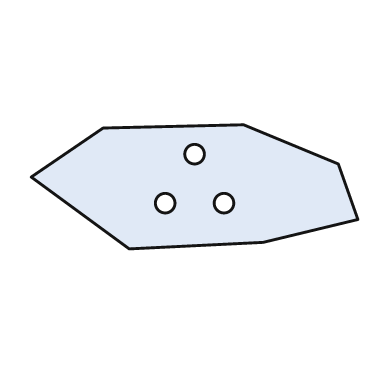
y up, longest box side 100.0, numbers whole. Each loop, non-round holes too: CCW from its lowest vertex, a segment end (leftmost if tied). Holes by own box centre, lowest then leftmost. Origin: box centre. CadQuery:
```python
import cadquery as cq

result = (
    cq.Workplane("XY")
    .moveTo(-20.0, -19.0)
    .lineTo(21.0, -17.0)
    .lineTo(50.0, -10.0)
    .lineTo(44.0, 7.0)
    .lineTo(15.0, 19.0)
    .lineTo(-28.0, 18.0)
    .lineTo(-50.0, 3.0)
    .close()
    .moveTo(-9.0, -5.0)
    .circle(3.0)
    .moveTo(9.0, -5.0)
    .circle(3.0)
    .moveTo(0.0, 10.0)
    .circle(3.0)
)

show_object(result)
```